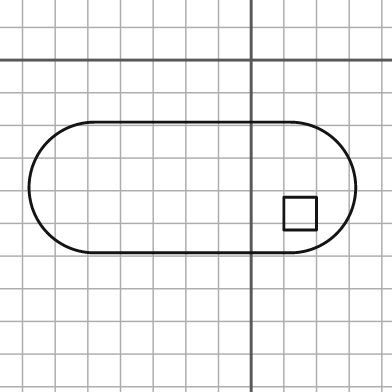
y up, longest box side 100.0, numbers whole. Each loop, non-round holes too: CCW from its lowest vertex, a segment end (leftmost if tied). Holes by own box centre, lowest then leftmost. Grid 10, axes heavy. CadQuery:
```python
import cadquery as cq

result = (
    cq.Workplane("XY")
    .moveTo(-48.0, -59.0)
    .lineTo(12.0, -59.0)
    .threePointArc((32.0, -39.0), (12.0, -19.0))
    .lineTo(-48.0, -19.0)
    .threePointArc((-68.0, -39.0), (-48.0, -59.0))
    .close()
    .moveTo(10.0, -52.0)
    .lineTo(20.0, -52.0)
    .lineTo(20.0, -42.0)
    .lineTo(10.0, -42.0)
    .close()
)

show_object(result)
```